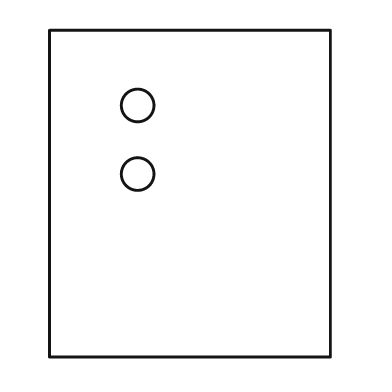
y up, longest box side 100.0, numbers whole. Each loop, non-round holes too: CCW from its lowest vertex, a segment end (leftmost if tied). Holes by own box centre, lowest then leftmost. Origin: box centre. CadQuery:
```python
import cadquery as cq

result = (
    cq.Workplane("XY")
    .moveTo(-43.0, -50.0)
    .lineTo(43.0, -50.0)
    .lineTo(43.0, 50.0)
    .lineTo(-43.0, 50.0)
    .close()
    .moveTo(-16.0, 6.0)
    .circle(5.0)
    .moveTo(-16.0, 27.0)
    .circle(5.0)
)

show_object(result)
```